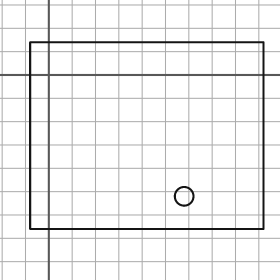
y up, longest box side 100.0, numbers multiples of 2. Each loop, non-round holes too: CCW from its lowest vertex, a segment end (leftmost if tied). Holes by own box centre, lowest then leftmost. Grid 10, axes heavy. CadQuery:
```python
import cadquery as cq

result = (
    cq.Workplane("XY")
    .moveTo(-8.0, -66.0)
    .lineTo(92.0, -66.0)
    .lineTo(92.0, 14.0)
    .lineTo(-8.0, 14.0)
    .close()
    .moveTo(58.0, -52.0)
    .circle(4.0)
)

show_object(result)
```